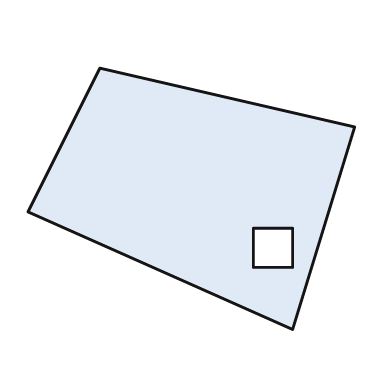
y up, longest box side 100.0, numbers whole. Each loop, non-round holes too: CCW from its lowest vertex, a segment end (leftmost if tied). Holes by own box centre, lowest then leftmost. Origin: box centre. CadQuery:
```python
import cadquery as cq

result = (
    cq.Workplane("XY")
    .moveTo(31.0, -40.0)
    .lineTo(50.0, 22.0)
    .lineTo(-28.0, 40.0)
    .lineTo(-50.0, -4.0)
    .close()
    .moveTo(19.0, -21.0)
    .lineTo(31.0, -21.0)
    .lineTo(31.0, -9.0)
    .lineTo(19.0, -9.0)
    .close()
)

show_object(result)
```